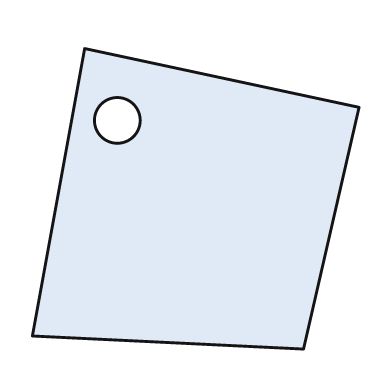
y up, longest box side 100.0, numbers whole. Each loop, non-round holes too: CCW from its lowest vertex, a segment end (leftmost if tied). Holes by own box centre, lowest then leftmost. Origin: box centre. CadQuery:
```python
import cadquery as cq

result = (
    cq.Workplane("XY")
    .moveTo(33.0, -46.0)
    .lineTo(50.0, 28.0)
    .lineTo(-34.0, 46.0)
    .lineTo(-50.0, -42.0)
    .close()
    .moveTo(-24.0, 24.0)
    .circle(7.0)
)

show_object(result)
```